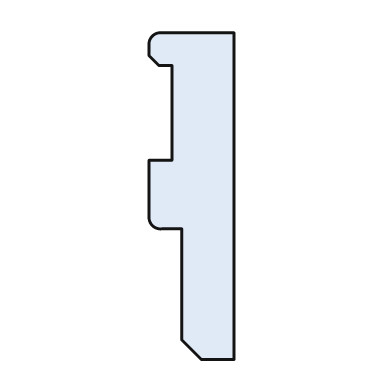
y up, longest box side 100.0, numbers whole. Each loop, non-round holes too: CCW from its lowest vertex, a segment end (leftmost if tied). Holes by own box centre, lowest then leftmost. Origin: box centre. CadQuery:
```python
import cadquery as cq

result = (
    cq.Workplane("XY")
    .moveTo(3.0, -50.0)
    .lineTo(13.0, -50.0)
    .lineTo(13.0, 50.0)
    .lineTo(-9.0, 50.0)
    .threePointArc((-12.0, 49.0), (-13.0, 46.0))
    .lineTo(-13.0, 43.0)
    .lineTo(-10.0, 40.0)
    .lineTo(-6.0, 40.0)
    .lineTo(-6.0, 11.0)
    .lineTo(-13.0, 11.0)
    .lineTo(-13.0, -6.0)
    .threePointArc((-12.0, -9.0), (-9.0, -10.0))
    .lineTo(-3.0, -10.0)
    .lineTo(-3.0, -44.0)
    .close()
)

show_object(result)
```